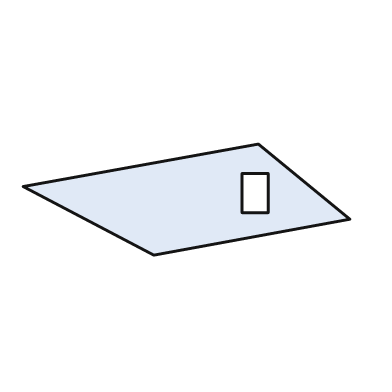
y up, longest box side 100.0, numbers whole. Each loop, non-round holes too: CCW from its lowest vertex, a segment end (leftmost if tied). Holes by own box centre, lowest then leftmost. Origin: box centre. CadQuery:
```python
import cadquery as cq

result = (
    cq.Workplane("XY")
    .moveTo(-10.0, -17.0)
    .lineTo(50.0, -6.0)
    .lineTo(22.0, 17.0)
    .lineTo(-50.0, 4.0)
    .close()
    .moveTo(17.0, -4.0)
    .lineTo(25.0, -4.0)
    .lineTo(25.0, 8.0)
    .lineTo(17.0, 8.0)
    .close()
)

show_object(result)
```